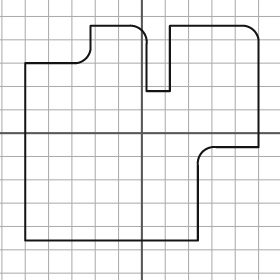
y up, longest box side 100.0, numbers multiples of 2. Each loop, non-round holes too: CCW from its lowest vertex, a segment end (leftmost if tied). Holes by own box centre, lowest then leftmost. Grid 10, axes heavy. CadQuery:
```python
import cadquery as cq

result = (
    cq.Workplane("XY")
    .moveTo(-50.0, -46.0)
    .lineTo(24.0, -46.0)
    .lineTo(24.0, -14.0)
    .threePointArc((26.0, -8.0), (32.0, -6.0))
    .lineTo(50.0, -6.0)
    .lineTo(50.0, 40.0)
    .threePointArc((48.0, 44.0), (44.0, 46.0))
    .lineTo(12.0, 46.0)
    .lineTo(12.0, 18.0)
    .lineTo(2.0, 18.0)
    .lineTo(2.0, 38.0)
    .threePointArc((0.0, 44.0), (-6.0, 46.0))
    .lineTo(-22.0, 46.0)
    .lineTo(-22.0, 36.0)
    .threePointArc((-24.0, 32.0), (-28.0, 30.0))
    .lineTo(-50.0, 30.0)
    .close()
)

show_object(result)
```